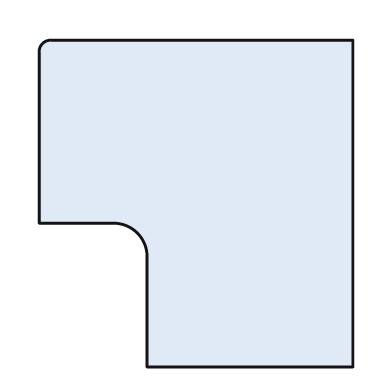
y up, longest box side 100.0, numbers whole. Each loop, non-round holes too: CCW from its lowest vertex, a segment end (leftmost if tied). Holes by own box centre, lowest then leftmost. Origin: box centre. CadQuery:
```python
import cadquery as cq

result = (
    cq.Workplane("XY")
    .moveTo(-15.0, -50.0)
    .lineTo(48.0, -50.0)
    .lineTo(48.0, 50.0)
    .lineTo(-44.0, 50.0)
    .threePointArc((-47.0, 49.0), (-48.0, 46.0))
    .lineTo(-48.0, -6.0)
    .lineTo(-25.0, -6.0)
    .threePointArc((-18.0, -9.0), (-15.0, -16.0))
    .close()
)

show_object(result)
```